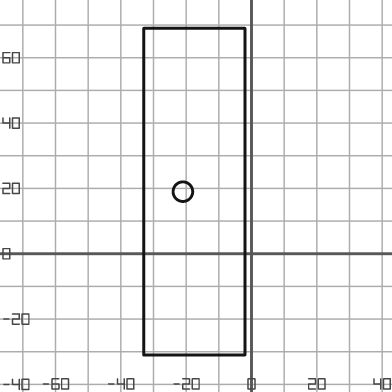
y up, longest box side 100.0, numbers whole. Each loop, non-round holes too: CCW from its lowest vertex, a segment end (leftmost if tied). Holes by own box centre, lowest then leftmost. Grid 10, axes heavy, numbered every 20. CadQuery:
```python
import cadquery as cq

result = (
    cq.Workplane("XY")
    .moveTo(-33.0, -31.0)
    .lineTo(-2.0, -31.0)
    .lineTo(-2.0, 69.0)
    .lineTo(-33.0, 69.0)
    .close()
    .moveTo(-21.0, 19.0)
    .circle(3.0)
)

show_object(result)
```